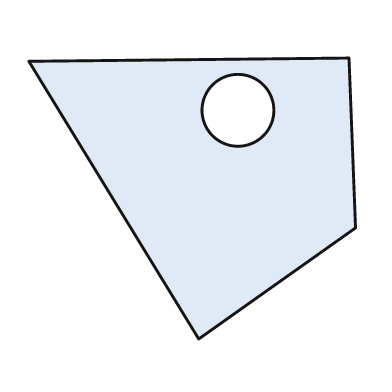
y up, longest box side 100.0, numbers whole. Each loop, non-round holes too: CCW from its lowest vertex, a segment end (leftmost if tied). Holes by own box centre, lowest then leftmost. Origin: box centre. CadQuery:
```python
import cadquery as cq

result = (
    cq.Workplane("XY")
    .moveTo(2.0, -43.0)
    .lineTo(50.0, -9.0)
    .lineTo(48.0, 43.0)
    .lineTo(-50.0, 42.0)
    .close()
    .moveTo(14.0, 27.0)
    .circle(11.0)
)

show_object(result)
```